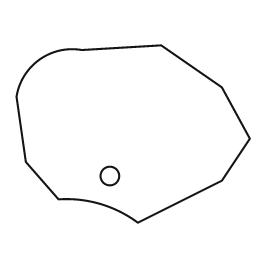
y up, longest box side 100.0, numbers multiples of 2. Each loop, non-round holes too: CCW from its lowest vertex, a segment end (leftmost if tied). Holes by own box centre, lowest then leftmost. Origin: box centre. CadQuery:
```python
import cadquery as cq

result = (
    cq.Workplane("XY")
    .moveTo(2.0, -38.0)
    .lineTo(38.0, -20.0)
    .lineTo(50.0, -2.0)
    .lineTo(38.0, 20.0)
    .lineTo(12.0, 38.0)
    .lineTo(-22.0, 36.0)
    .threePointArc((-40.0, 32.0), (-50.0, 16.0))
    .lineTo(-46.0, -12.0)
    .lineTo(-32.0, -28.0)
    .threePointArc((-14.0, -30.0), (2.0, -38.0))
    .close()
    .moveTo(-10.0, -18.0)
    .circle(4.0)
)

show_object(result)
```